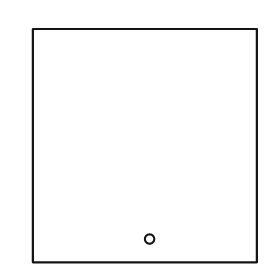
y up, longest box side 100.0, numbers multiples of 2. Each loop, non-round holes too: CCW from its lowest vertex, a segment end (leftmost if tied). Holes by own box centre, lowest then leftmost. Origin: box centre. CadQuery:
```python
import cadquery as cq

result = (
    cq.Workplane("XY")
    .moveTo(-48.0, -50.0)
    .lineTo(48.0, -50.0)
    .lineTo(48.0, 50.0)
    .lineTo(-48.0, 50.0)
    .close()
    .moveTo(2.0, -40.0)
    .circle(2.0)
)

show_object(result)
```